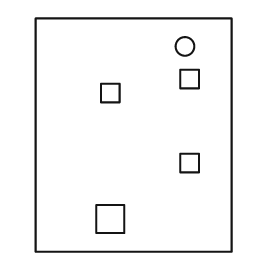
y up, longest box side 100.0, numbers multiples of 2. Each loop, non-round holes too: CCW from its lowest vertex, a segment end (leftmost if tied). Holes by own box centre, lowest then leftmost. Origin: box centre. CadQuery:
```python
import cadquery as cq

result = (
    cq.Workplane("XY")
    .moveTo(-42.0, -50.0)
    .lineTo(42.0, -50.0)
    .lineTo(42.0, 50.0)
    .lineTo(-42.0, 50.0)
    .close()
    .moveTo(-16.0, -42.0)
    .lineTo(-4.0, -42.0)
    .lineTo(-4.0, -30.0)
    .lineTo(-16.0, -30.0)
    .close()
    .moveTo(20.0, -16.0)
    .lineTo(28.0, -16.0)
    .lineTo(28.0, -8.0)
    .lineTo(20.0, -8.0)
    .close()
    .moveTo(-14.0, 14.0)
    .lineTo(-6.0, 14.0)
    .lineTo(-6.0, 22.0)
    .lineTo(-14.0, 22.0)
    .close()
    .moveTo(20.0, 20.0)
    .lineTo(28.0, 20.0)
    .lineTo(28.0, 28.0)
    .lineTo(20.0, 28.0)
    .close()
    .moveTo(22.0, 38.0)
    .circle(4.0)
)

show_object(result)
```